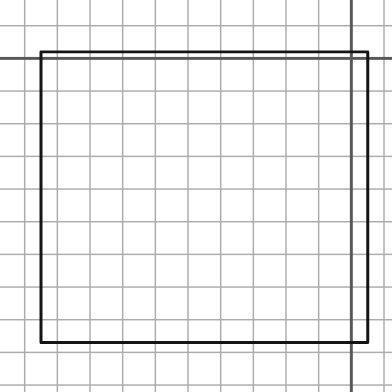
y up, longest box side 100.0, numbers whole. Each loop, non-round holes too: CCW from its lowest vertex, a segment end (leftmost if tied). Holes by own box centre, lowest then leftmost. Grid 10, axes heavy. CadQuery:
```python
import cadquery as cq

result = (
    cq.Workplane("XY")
    .moveTo(-95.0, -87.0)
    .lineTo(5.0, -87.0)
    .lineTo(5.0, 2.0)
    .lineTo(-95.0, 2.0)
    .close()
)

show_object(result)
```